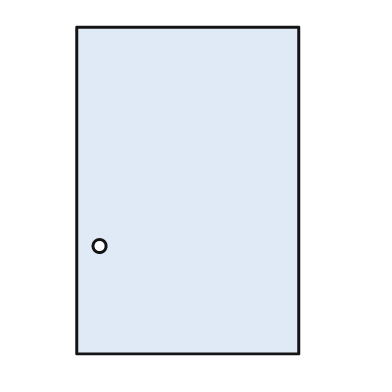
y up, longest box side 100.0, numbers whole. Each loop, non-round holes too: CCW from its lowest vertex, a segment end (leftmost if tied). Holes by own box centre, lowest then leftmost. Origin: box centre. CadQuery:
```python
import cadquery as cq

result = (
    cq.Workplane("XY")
    .moveTo(-34.0, -50.0)
    .lineTo(34.0, -50.0)
    .lineTo(34.0, 50.0)
    .lineTo(-34.0, 50.0)
    .close()
    .moveTo(-27.0, -17.0)
    .circle(2.0)
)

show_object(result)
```